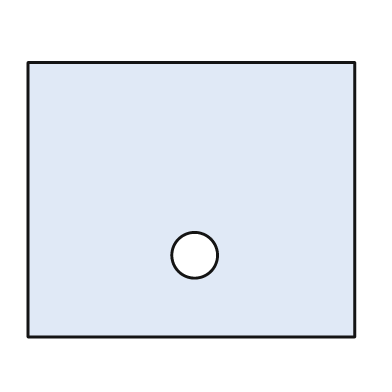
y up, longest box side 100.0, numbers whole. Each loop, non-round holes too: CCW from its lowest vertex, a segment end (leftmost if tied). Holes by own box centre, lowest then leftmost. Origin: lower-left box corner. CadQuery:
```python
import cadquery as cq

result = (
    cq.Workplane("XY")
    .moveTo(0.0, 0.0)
    .lineTo(100.0, 0.0)
    .lineTo(100.0, 84.0)
    .lineTo(0.0, 84.0)
    .close()
    .moveTo(51.0, 25.0)
    .circle(7.0)
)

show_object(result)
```